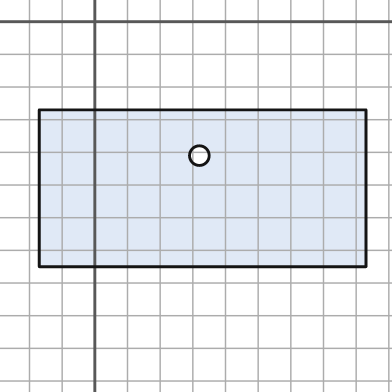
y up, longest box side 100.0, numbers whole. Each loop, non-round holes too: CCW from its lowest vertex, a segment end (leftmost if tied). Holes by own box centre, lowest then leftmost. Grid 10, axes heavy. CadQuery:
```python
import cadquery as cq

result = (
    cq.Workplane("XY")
    .moveTo(-17.0, -75.0)
    .lineTo(83.0, -75.0)
    .lineTo(83.0, -27.0)
    .lineTo(-17.0, -27.0)
    .close()
    .moveTo(32.0, -41.0)
    .circle(3.0)
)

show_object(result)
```